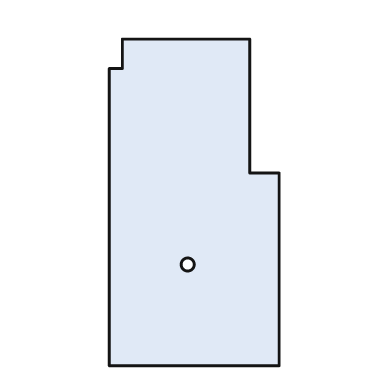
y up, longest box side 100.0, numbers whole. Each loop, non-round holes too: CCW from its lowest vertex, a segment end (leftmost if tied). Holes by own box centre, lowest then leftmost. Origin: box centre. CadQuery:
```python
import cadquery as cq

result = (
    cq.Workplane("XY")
    .moveTo(-26.0, -50.0)
    .lineTo(26.0, -50.0)
    .lineTo(26.0, 9.0)
    .lineTo(17.0, 9.0)
    .lineTo(17.0, 50.0)
    .lineTo(-22.0, 50.0)
    .lineTo(-22.0, 41.0)
    .lineTo(-26.0, 41.0)
    .close()
    .moveTo(-2.0, -19.0)
    .circle(2.0)
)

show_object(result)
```